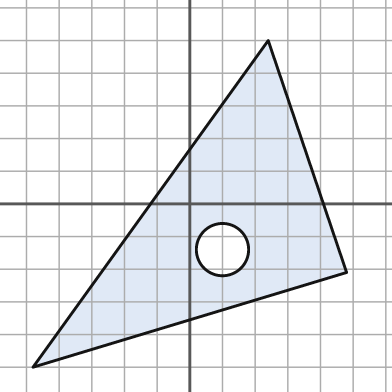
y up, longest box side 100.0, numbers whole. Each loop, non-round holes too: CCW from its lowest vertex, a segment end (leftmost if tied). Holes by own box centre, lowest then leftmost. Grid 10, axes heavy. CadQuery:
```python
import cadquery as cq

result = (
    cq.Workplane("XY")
    .moveTo(-48.0, -50.0)
    .lineTo(48.0, -21.0)
    .lineTo(24.0, 50.0)
    .close()
    .moveTo(10.0, -14.0)
    .circle(8.0)
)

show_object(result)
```